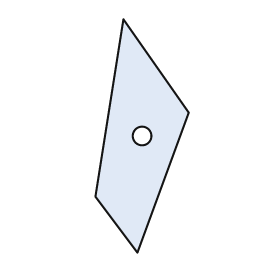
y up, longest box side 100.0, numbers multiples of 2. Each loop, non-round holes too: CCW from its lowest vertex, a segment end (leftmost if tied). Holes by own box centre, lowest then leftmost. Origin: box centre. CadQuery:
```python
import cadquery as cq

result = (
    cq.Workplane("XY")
    .moveTo(-2.0, -50.0)
    .lineTo(20.0, 10.0)
    .lineTo(-8.0, 50.0)
    .lineTo(-20.0, -26.0)
    .close()
    .moveTo(0.0, 0.0)
    .circle(4.0)
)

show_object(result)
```